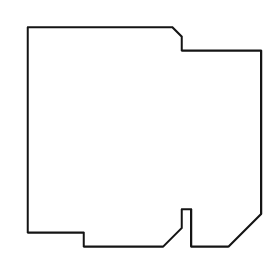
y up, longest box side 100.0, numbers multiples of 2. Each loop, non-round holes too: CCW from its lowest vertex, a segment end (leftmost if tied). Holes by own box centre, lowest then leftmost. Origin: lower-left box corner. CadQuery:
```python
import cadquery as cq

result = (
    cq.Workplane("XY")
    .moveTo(24.0, 0.0)
    .lineTo(58.0, 0.0)
    .lineTo(66.0, 8.0)
    .lineTo(66.0, 16.0)
    .lineTo(70.0, 16.0)
    .lineTo(70.0, 0.0)
    .lineTo(86.0, 0.0)
    .lineTo(100.0, 14.0)
    .lineTo(100.0, 84.0)
    .lineTo(66.0, 84.0)
    .lineTo(66.0, 90.0)
    .lineTo(62.0, 94.0)
    .lineTo(0.0, 94.0)
    .lineTo(0.0, 6.0)
    .lineTo(24.0, 6.0)
    .close()
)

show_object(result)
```